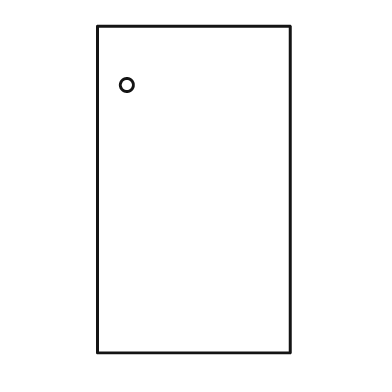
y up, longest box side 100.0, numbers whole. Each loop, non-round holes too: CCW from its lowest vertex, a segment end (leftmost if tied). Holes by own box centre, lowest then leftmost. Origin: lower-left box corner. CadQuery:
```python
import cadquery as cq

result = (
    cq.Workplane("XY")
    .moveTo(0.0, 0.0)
    .lineTo(59.0, 0.0)
    .lineTo(59.0, 100.0)
    .lineTo(0.0, 100.0)
    .close()
    .moveTo(9.0, 82.0)
    .circle(2.0)
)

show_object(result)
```